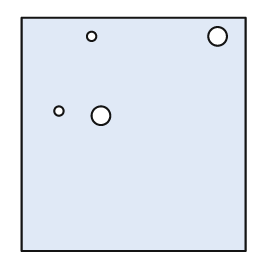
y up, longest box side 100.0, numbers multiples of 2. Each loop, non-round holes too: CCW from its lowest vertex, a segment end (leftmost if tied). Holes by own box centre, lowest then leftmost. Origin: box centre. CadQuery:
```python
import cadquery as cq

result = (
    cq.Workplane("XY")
    .moveTo(-48.0, -50.0)
    .lineTo(48.0, -50.0)
    .lineTo(48.0, 50.0)
    .lineTo(-48.0, 50.0)
    .close()
    .moveTo(-14.0, 8.0)
    .circle(4.0)
    .moveTo(-32.0, 10.0)
    .circle(2.0)
    .moveTo(-18.0, 42.0)
    .circle(2.0)
    .moveTo(36.0, 42.0)
    .circle(4.0)
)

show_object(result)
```